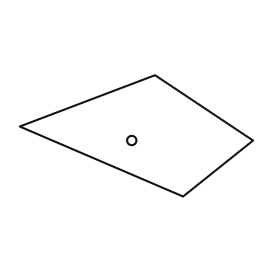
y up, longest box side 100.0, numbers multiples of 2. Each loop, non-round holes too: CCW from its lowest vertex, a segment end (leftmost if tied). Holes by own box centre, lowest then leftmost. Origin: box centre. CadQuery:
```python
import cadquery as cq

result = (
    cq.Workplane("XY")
    .moveTo(20.0, -26.0)
    .lineTo(50.0, -2.0)
    .lineTo(8.0, 26.0)
    .lineTo(-50.0, 4.0)
    .close()
    .moveTo(-2.0, -2.0)
    .circle(2.0)
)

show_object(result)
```